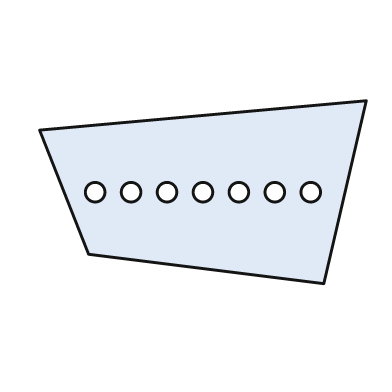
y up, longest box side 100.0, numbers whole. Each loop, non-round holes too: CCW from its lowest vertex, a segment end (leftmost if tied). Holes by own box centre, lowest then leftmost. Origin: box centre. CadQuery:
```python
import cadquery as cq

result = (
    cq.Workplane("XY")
    .moveTo(37.0, -28.0)
    .lineTo(50.0, 28.0)
    .lineTo(-50.0, 19.0)
    .lineTo(-35.0, -19.0)
    .close()
    .moveTo(-33.0, 0.0)
    .circle(3.0)
    .moveTo(-22.0, 0.0)
    .circle(3.0)
    .moveTo(-11.0, 0.0)
    .circle(3.0)
    .moveTo(0.0, 0.0)
    .circle(3.0)
    .moveTo(11.0, 0.0)
    .circle(3.0)
    .moveTo(22.0, 0.0)
    .circle(3.0)
    .moveTo(33.0, 0.0)
    .circle(3.0)
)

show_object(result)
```